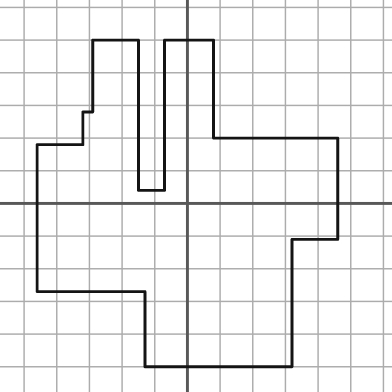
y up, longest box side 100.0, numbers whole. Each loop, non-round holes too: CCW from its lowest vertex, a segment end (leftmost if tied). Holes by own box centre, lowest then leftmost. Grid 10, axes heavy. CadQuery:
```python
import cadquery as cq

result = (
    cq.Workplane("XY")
    .moveTo(-13.0, -50.0)
    .lineTo(32.0, -50.0)
    .lineTo(32.0, -11.0)
    .lineTo(46.0, -11.0)
    .lineTo(46.0, 20.0)
    .lineTo(8.0, 20.0)
    .lineTo(8.0, 50.0)
    .lineTo(-7.0, 50.0)
    .lineTo(-7.0, 4.0)
    .lineTo(-15.0, 4.0)
    .lineTo(-15.0, 50.0)
    .lineTo(-29.0, 50.0)
    .lineTo(-29.0, 28.0)
    .lineTo(-32.0, 28.0)
    .lineTo(-32.0, 18.0)
    .lineTo(-46.0, 18.0)
    .lineTo(-46.0, -27.0)
    .lineTo(-13.0, -27.0)
    .close()
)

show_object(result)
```